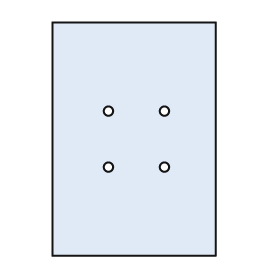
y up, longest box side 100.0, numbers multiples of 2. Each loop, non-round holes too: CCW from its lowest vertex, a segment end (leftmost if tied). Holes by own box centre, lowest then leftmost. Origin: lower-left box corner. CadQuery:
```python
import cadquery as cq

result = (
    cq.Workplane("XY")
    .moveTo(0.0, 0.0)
    .lineTo(70.0, 0.0)
    .lineTo(70.0, 100.0)
    .lineTo(0.0, 100.0)
    .close()
    .moveTo(24.0, 38.0)
    .circle(2.0)
    .moveTo(48.0, 38.0)
    .circle(2.0)
    .moveTo(24.0, 62.0)
    .circle(2.0)
    .moveTo(48.0, 62.0)
    .circle(2.0)
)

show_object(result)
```